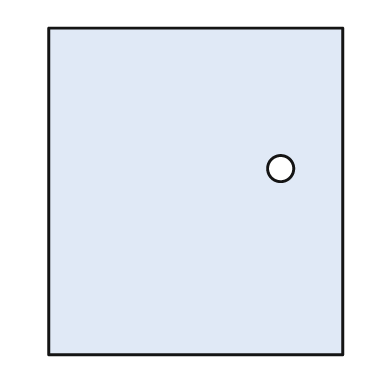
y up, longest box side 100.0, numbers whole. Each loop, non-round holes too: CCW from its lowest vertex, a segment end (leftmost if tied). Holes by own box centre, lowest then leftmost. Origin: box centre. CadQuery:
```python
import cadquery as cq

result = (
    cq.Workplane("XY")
    .moveTo(-45.0, -50.0)
    .lineTo(45.0, -50.0)
    .lineTo(45.0, 50.0)
    .lineTo(-45.0, 50.0)
    .close()
    .moveTo(26.0, 7.0)
    .circle(4.0)
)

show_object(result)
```